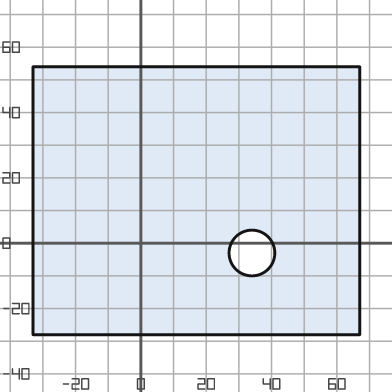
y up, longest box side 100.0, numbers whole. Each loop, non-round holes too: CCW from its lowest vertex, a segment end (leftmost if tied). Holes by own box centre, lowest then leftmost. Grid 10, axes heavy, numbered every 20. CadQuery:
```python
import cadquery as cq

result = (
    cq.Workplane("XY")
    .moveTo(-33.0, -28.0)
    .lineTo(67.0, -28.0)
    .lineTo(67.0, 54.0)
    .lineTo(-33.0, 54.0)
    .close()
    .moveTo(34.0, -3.0)
    .circle(7.0)
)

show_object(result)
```